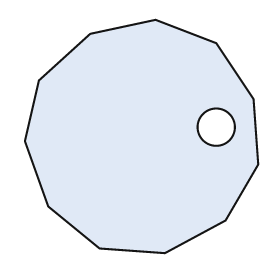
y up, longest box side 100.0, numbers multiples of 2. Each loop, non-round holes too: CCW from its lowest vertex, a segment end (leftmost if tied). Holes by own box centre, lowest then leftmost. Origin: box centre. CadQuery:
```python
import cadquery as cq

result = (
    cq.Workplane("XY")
    .moveTo(10.0, -50.0)
    .lineTo(36.0, -36.0)
    .lineTo(50.0, -12.0)
    .lineTo(48.0, 16.0)
    .lineTo(32.0, 40.0)
    .lineTo(6.0, 50.0)
    .lineTo(-22.0, 44.0)
    .lineTo(-44.0, 24.0)
    .lineTo(-50.0, -2.0)
    .lineTo(-40.0, -30.0)
    .lineTo(-18.0, -48.0)
    .close()
    .moveTo(32.0, 4.0)
    .circle(8.0)
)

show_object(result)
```